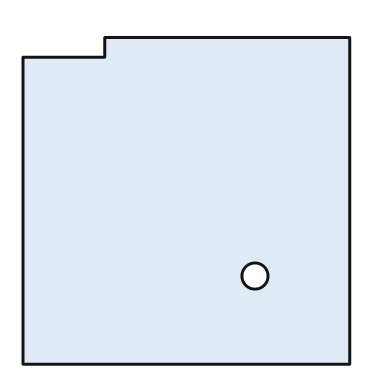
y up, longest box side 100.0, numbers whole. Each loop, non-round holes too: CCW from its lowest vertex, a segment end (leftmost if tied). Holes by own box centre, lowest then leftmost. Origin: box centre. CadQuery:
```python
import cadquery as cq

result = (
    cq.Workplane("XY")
    .moveTo(-50.0, -50.0)
    .lineTo(50.0, -50.0)
    .lineTo(50.0, 50.0)
    .lineTo(-25.0, 50.0)
    .lineTo(-25.0, 44.0)
    .lineTo(-50.0, 44.0)
    .close()
    .moveTo(21.0, -23.0)
    .circle(4.0)
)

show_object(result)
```